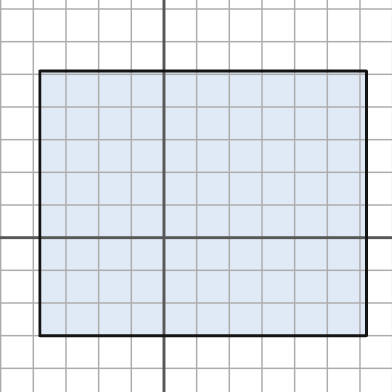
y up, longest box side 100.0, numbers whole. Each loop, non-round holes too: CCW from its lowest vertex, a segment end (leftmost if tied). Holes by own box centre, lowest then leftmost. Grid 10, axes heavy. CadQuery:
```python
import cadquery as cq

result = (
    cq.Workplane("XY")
    .moveTo(-38.0, -30.0)
    .lineTo(62.0, -30.0)
    .lineTo(62.0, 51.0)
    .lineTo(-38.0, 51.0)
    .close()
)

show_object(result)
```